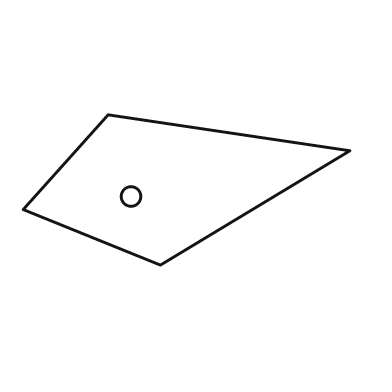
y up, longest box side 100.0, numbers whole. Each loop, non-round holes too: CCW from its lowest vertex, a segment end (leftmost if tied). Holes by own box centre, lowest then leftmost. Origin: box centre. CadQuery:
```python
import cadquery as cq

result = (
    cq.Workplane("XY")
    .moveTo(-8.0, -23.0)
    .lineTo(50.0, 12.0)
    .lineTo(-24.0, 23.0)
    .lineTo(-50.0, -6.0)
    .close()
    .moveTo(-17.0, -2.0)
    .circle(3.0)
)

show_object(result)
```